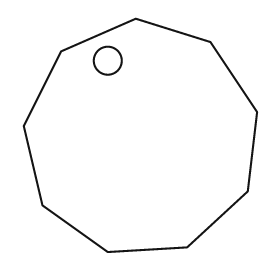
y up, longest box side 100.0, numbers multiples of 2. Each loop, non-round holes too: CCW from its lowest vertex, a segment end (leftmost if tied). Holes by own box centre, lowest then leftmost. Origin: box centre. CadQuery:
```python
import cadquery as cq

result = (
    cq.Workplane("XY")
    .moveTo(-14.0, -50.0)
    .lineTo(20.0, -48.0)
    .lineTo(46.0, -24.0)
    .lineTo(50.0, 10.0)
    .lineTo(30.0, 40.0)
    .lineTo(-2.0, 50.0)
    .lineTo(-34.0, 36.0)
    .lineTo(-50.0, 4.0)
    .lineTo(-42.0, -30.0)
    .close()
    .moveTo(-14.0, 32.0)
    .circle(6.0)
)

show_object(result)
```